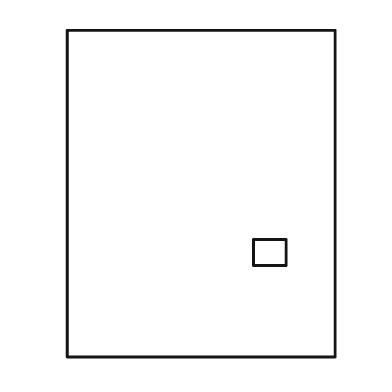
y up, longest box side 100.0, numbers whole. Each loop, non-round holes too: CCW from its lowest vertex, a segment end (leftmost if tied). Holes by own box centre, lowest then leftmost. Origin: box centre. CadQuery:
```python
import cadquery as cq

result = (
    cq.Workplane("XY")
    .moveTo(-41.0, -50.0)
    .lineTo(41.0, -50.0)
    .lineTo(41.0, 50.0)
    .lineTo(-41.0, 50.0)
    .close()
    .moveTo(16.0, -22.0)
    .lineTo(26.0, -22.0)
    .lineTo(26.0, -14.0)
    .lineTo(16.0, -14.0)
    .close()
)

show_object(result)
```